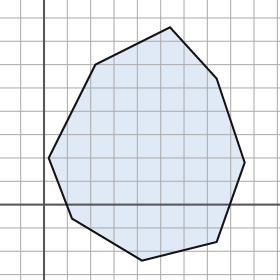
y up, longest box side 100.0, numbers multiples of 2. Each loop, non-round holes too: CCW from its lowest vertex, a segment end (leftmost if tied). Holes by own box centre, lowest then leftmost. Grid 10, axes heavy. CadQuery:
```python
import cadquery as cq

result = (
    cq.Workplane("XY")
    .moveTo(42.0, -24.0)
    .lineTo(74.0, -16.0)
    .lineTo(86.0, 18.0)
    .lineTo(74.0, 54.0)
    .lineTo(54.0, 76.0)
    .lineTo(22.0, 60.0)
    .lineTo(2.0, 20.0)
    .lineTo(12.0, -6.0)
    .close()
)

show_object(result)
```